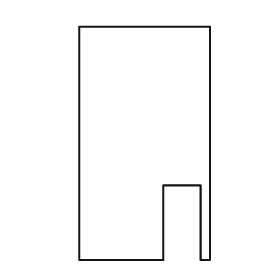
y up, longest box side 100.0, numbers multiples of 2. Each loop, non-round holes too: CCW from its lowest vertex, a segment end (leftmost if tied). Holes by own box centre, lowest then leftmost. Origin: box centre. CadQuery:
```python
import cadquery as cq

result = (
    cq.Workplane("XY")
    .moveTo(-28.0, -50.0)
    .lineTo(8.0, -50.0)
    .lineTo(8.0, -18.0)
    .lineTo(24.0, -18.0)
    .lineTo(24.0, -50.0)
    .lineTo(28.0, -50.0)
    .lineTo(28.0, 50.0)
    .lineTo(-28.0, 50.0)
    .close()
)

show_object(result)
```